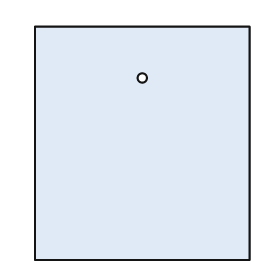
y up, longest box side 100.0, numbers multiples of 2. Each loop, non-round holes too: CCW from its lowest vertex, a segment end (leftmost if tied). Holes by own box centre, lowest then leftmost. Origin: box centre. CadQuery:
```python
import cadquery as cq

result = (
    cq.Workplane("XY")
    .moveTo(-46.0, -50.0)
    .lineTo(46.0, -50.0)
    .lineTo(46.0, 50.0)
    .lineTo(-46.0, 50.0)
    .close()
    .moveTo(0.0, 28.0)
    .circle(2.0)
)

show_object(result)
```